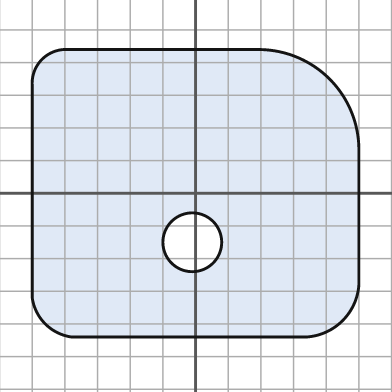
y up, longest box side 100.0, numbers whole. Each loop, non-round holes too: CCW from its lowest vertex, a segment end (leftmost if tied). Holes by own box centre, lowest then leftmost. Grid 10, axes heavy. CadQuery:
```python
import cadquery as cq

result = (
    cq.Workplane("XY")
    .moveTo(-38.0, -44.0)
    .lineTo(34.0, -44.0)
    .threePointArc((45.0, -39.0), (50.0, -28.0))
    .lineTo(50.0, 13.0)
    .threePointArc((41.0, 35.0), (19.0, 44.0))
    .lineTo(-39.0, 44.0)
    .threePointArc((-47.0, 41.0), (-50.0, 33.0))
    .lineTo(-50.0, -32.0)
    .threePointArc((-46.0, -40.0), (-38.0, -44.0))
    .close()
    .moveTo(-1.0, -15.0)
    .circle(9.0)
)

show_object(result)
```